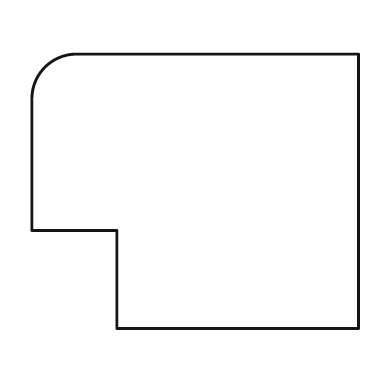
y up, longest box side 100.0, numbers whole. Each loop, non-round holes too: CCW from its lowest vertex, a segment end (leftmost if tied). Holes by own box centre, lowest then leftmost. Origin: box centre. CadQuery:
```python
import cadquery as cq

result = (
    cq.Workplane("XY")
    .moveTo(-24.0, -42.0)
    .lineTo(50.0, -42.0)
    .lineTo(50.0, 42.0)
    .lineTo(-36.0, 42.0)
    .threePointArc((-46.0, 38.0), (-50.0, 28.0))
    .lineTo(-50.0, -12.0)
    .lineTo(-24.0, -12.0)
    .close()
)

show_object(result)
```